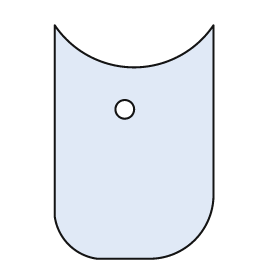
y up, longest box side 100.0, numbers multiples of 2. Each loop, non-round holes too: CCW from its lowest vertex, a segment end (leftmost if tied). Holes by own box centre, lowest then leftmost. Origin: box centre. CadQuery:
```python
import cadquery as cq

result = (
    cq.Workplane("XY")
    .moveTo(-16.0, -50.0)
    .lineTo(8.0, -50.0)
    .threePointArc((26.0, -42.0), (34.0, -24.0))
    .lineTo(34.0, 50.0)
    .threePointArc((0.0, 32.0), (-34.0, 50.0))
    .lineTo(-34.0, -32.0)
    .threePointArc((-28.0, -44.0), (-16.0, -50.0))
    .close()
    .moveTo(-4.0, 14.0)
    .circle(4.0)
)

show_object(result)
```